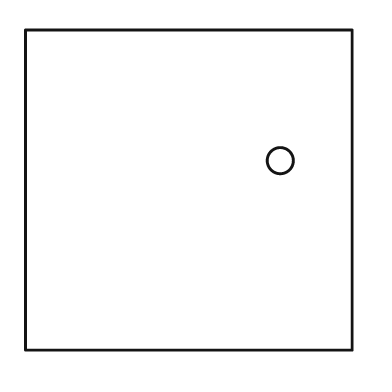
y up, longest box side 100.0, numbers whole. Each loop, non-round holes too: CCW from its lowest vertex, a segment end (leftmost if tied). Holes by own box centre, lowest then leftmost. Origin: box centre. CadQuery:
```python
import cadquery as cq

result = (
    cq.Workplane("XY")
    .moveTo(-50.0, -49.0)
    .lineTo(50.0, -49.0)
    .lineTo(50.0, 49.0)
    .lineTo(-50.0, 49.0)
    .close()
    .moveTo(28.0, 9.0)
    .circle(4.0)
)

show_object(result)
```